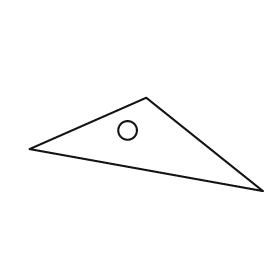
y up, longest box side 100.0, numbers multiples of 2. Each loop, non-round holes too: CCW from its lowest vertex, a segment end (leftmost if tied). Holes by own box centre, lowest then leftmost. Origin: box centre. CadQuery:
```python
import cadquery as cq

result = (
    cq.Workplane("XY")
    .moveTo(50.0, -20.0)
    .lineTo(0.0, 20.0)
    .lineTo(-50.0, -2.0)
    .close()
    .moveTo(-8.0, 6.0)
    .circle(4.0)
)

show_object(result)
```